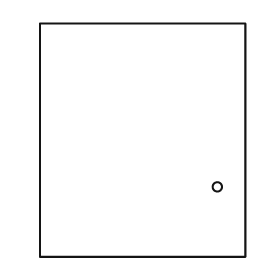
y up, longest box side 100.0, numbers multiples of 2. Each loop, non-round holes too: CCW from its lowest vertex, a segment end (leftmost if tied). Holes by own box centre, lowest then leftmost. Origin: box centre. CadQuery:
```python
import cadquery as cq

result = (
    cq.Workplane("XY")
    .moveTo(-44.0, -50.0)
    .lineTo(44.0, -50.0)
    .lineTo(44.0, 50.0)
    .lineTo(-44.0, 50.0)
    .close()
    .moveTo(32.0, -20.0)
    .circle(2.0)
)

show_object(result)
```